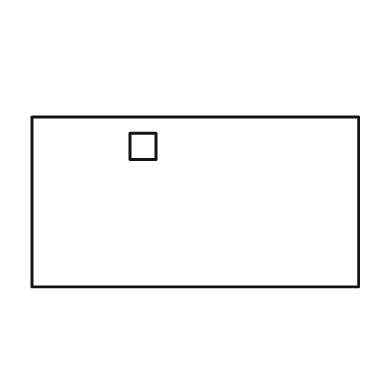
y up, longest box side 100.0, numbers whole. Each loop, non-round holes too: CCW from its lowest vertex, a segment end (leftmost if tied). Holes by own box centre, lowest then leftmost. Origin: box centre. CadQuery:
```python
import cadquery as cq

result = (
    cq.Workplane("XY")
    .moveTo(-50.0, -26.0)
    .lineTo(50.0, -26.0)
    .lineTo(50.0, 26.0)
    .lineTo(-50.0, 26.0)
    .close()
    .moveTo(-20.0, 13.0)
    .lineTo(-12.0, 13.0)
    .lineTo(-12.0, 21.0)
    .lineTo(-20.0, 21.0)
    .close()
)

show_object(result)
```